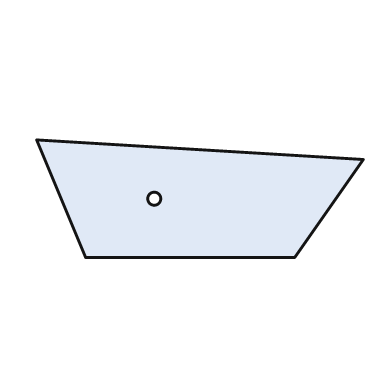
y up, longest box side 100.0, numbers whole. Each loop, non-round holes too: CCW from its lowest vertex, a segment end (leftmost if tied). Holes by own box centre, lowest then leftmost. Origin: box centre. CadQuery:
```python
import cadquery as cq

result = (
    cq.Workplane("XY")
    .moveTo(-35.0, -18.0)
    .lineTo(29.0, -18.0)
    .lineTo(50.0, 12.0)
    .lineTo(-50.0, 18.0)
    .close()
    .moveTo(-14.0, 0.0)
    .circle(2.0)
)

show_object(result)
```